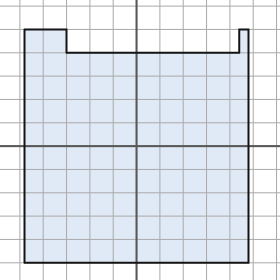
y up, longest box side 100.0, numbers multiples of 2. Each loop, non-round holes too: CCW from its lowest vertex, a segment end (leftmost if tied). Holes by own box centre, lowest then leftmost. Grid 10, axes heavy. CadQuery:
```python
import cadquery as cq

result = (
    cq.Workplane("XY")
    .moveTo(-48.0, -50.0)
    .lineTo(48.0, -50.0)
    .lineTo(48.0, 50.0)
    .lineTo(44.0, 50.0)
    .lineTo(44.0, 40.0)
    .lineTo(-30.0, 40.0)
    .lineTo(-30.0, 50.0)
    .lineTo(-48.0, 50.0)
    .close()
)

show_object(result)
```